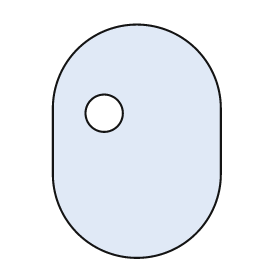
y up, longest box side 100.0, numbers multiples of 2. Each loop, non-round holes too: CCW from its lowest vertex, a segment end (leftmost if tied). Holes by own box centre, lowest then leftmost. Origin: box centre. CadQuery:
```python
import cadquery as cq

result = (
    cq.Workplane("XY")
    .moveTo(-36.0, -14.0)
    .threePointArc((0.0, -50.0), (36.0, -14.0))
    .lineTo(36.0, 14.0)
    .threePointArc((0.0, 50.0), (-36.0, 14.0))
    .close()
    .moveTo(-14.0, 12.0)
    .circle(8.0)
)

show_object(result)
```